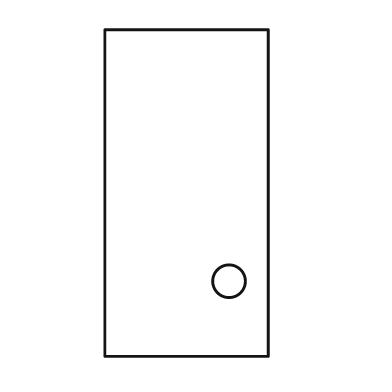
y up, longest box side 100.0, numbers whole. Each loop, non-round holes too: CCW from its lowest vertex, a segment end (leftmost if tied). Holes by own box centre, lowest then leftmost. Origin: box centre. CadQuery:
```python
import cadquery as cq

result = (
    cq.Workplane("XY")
    .moveTo(-25.0, -50.0)
    .lineTo(25.0, -50.0)
    .lineTo(25.0, 50.0)
    .lineTo(-25.0, 50.0)
    .close()
    .moveTo(13.0, -27.0)
    .circle(5.0)
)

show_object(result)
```